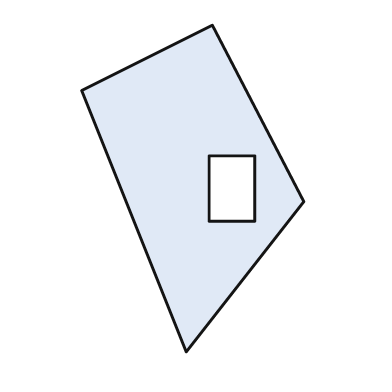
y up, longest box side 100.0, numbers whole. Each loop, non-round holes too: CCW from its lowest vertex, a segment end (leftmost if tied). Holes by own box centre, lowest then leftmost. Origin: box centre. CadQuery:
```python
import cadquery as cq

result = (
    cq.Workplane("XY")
    .moveTo(-2.0, -50.0)
    .lineTo(34.0, -4.0)
    .lineTo(6.0, 50.0)
    .lineTo(-34.0, 30.0)
    .close()
    .moveTo(5.0, -10.0)
    .lineTo(19.0, -10.0)
    .lineTo(19.0, 10.0)
    .lineTo(5.0, 10.0)
    .close()
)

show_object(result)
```